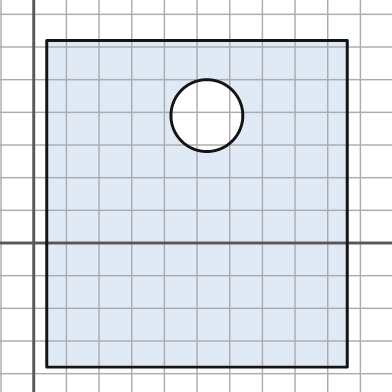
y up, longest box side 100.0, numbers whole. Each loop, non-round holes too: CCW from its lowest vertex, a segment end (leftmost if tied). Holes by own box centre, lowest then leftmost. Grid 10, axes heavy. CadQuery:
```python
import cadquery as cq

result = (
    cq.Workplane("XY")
    .moveTo(4.0, -38.0)
    .lineTo(96.0, -38.0)
    .lineTo(96.0, 62.0)
    .lineTo(4.0, 62.0)
    .close()
    .moveTo(53.0, 39.0)
    .circle(11.0)
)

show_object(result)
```